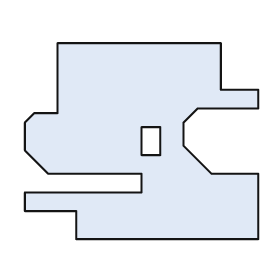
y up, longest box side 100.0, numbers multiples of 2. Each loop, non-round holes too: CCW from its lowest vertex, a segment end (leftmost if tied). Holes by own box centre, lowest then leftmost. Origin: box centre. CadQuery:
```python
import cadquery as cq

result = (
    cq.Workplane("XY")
    .moveTo(-28.0, -42.0)
    .lineTo(50.0, -42.0)
    .lineTo(50.0, -14.0)
    .lineTo(30.0, -14.0)
    .lineTo(18.0, -2.0)
    .lineTo(18.0, 8.0)
    .lineTo(24.0, 14.0)
    .lineTo(50.0, 14.0)
    .lineTo(50.0, 22.0)
    .lineTo(34.0, 22.0)
    .lineTo(34.0, 42.0)
    .lineTo(-36.0, 42.0)
    .lineTo(-36.0, 12.0)
    .lineTo(-46.0, 12.0)
    .lineTo(-50.0, 8.0)
    .lineTo(-50.0, -4.0)
    .lineTo(-40.0, -14.0)
    .lineTo(0.0, -14.0)
    .lineTo(0.0, -22.0)
    .lineTo(-50.0, -22.0)
    .lineTo(-50.0, -30.0)
    .lineTo(-28.0, -30.0)
    .close()
    .moveTo(0.0, -6.0)
    .lineTo(8.0, -6.0)
    .lineTo(8.0, 6.0)
    .lineTo(0.0, 6.0)
    .close()
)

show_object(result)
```